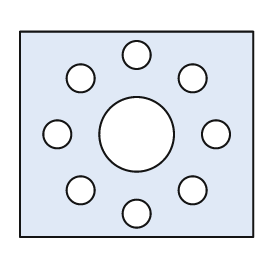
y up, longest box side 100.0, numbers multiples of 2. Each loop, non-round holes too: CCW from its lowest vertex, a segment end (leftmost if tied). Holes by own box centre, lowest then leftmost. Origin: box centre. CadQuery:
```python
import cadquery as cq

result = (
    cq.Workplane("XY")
    .moveTo(-50.0, -44.0)
    .lineTo(50.0, -44.0)
    .lineTo(50.0, 44.0)
    .lineTo(-50.0, 44.0)
    .close()
    .moveTo(0.0, -34.0)
    .circle(6.0)
    .moveTo(-24.0, -24.0)
    .circle(6.0)
    .moveTo(24.0, -24.0)
    .circle(6.0)
    .moveTo(-34.0, 0.0)
    .circle(6.0)
    .moveTo(0.0, 0.0)
    .circle(16.0)
    .moveTo(34.0, 0.0)
    .circle(6.0)
    .moveTo(-24.0, 24.0)
    .circle(6.0)
    .moveTo(24.0, 24.0)
    .circle(6.0)
    .moveTo(0.0, 34.0)
    .circle(6.0)
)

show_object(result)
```